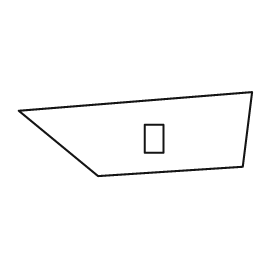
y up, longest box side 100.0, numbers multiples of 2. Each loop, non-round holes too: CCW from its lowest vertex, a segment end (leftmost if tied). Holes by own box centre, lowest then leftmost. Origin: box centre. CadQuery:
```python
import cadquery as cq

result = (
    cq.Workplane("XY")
    .moveTo(-16.0, -18.0)
    .lineTo(46.0, -14.0)
    .lineTo(50.0, 18.0)
    .lineTo(-50.0, 10.0)
    .close()
    .moveTo(4.0, -8.0)
    .lineTo(12.0, -8.0)
    .lineTo(12.0, 4.0)
    .lineTo(4.0, 4.0)
    .close()
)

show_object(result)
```